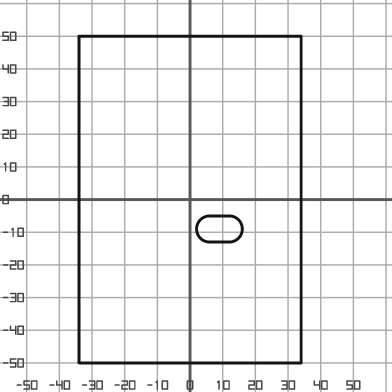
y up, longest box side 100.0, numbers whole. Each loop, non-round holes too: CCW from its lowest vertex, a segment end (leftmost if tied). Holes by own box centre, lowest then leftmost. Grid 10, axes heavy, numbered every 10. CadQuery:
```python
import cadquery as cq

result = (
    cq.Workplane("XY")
    .moveTo(-34.0, -50.0)
    .lineTo(34.0, -50.0)
    .lineTo(34.0, 50.0)
    .lineTo(-34.0, 50.0)
    .close()
    .moveTo(6.0, -13.0)
    .lineTo(12.0, -13.0)
    .threePointArc((16.0, -9.0), (12.0, -5.0))
    .lineTo(6.0, -5.0)
    .threePointArc((2.0, -9.0), (6.0, -13.0))
    .close()
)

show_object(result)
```